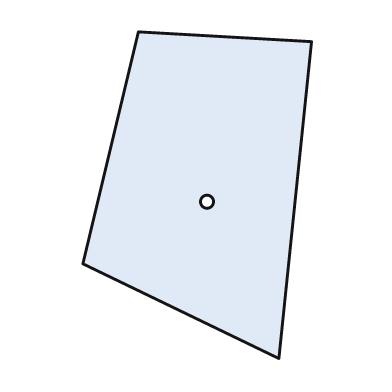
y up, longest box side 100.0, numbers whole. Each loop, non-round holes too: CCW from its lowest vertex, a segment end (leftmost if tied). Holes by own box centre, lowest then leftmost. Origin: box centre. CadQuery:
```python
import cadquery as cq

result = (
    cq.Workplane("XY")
    .moveTo(25.0, -50.0)
    .lineTo(35.0, 47.0)
    .lineTo(-18.0, 50.0)
    .lineTo(-35.0, -21.0)
    .close()
    .moveTo(3.0, -2.0)
    .circle(2.0)
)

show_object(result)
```